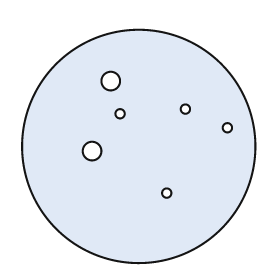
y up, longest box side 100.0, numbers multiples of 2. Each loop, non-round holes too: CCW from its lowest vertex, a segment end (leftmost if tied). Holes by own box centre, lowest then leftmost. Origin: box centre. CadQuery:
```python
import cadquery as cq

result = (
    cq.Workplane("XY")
    .moveTo(0.0, 0.0)
    .circle(50.0)
    .moveTo(12.0, -20.0)
    .circle(2.0)
    .moveTo(-20.0, -2.0)
    .circle(4.0)
    .moveTo(38.0, 8.0)
    .circle(2.0)
    .moveTo(-8.0, 14.0)
    .circle(2.0)
    .moveTo(20.0, 16.0)
    .circle(2.0)
    .moveTo(-12.0, 28.0)
    .circle(4.0)
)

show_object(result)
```